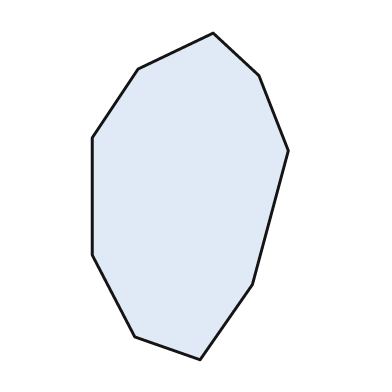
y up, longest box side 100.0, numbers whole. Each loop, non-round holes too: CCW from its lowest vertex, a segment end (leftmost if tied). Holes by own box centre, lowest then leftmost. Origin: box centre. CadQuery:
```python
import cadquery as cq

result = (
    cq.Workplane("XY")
    .moveTo(3.0, -50.0)
    .lineTo(19.0, -27.0)
    .lineTo(30.0, 14.0)
    .lineTo(21.0, 37.0)
    .lineTo(7.0, 50.0)
    .lineTo(-16.0, 39.0)
    .lineTo(-30.0, 18.0)
    .lineTo(-30.0, -18.0)
    .lineTo(-17.0, -43.0)
    .close()
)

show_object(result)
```